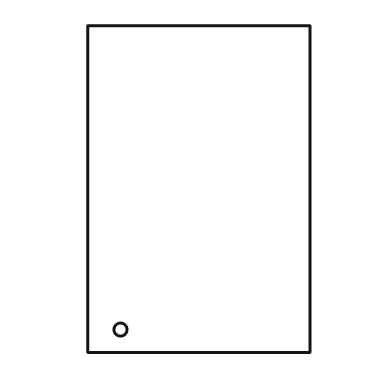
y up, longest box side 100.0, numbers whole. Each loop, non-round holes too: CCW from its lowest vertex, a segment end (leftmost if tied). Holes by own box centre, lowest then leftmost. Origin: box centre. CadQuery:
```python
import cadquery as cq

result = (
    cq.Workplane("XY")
    .moveTo(-34.0, -50.0)
    .lineTo(34.0, -50.0)
    .lineTo(34.0, 50.0)
    .lineTo(-34.0, 50.0)
    .close()
    .moveTo(-24.0, -43.0)
    .circle(2.0)
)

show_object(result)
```